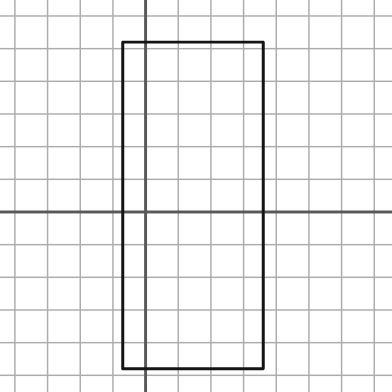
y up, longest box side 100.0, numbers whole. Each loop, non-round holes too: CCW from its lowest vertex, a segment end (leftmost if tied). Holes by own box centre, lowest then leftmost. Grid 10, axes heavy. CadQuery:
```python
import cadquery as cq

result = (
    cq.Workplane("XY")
    .moveTo(-7.0, -48.0)
    .lineTo(36.0, -48.0)
    .lineTo(36.0, 52.0)
    .lineTo(-7.0, 52.0)
    .close()
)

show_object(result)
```